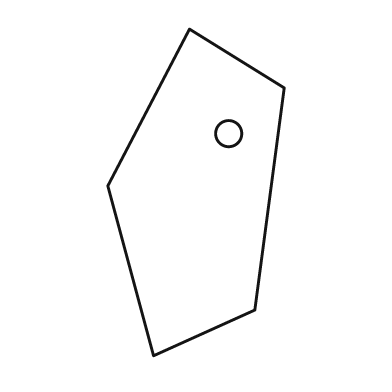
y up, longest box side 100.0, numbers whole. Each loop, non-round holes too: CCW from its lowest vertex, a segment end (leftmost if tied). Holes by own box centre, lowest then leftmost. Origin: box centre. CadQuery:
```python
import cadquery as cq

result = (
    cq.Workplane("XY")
    .moveTo(-13.0, -50.0)
    .lineTo(18.0, -36.0)
    .lineTo(27.0, 32.0)
    .lineTo(-2.0, 50.0)
    .lineTo(-27.0, 2.0)
    .close()
    .moveTo(10.0, 18.0)
    .circle(4.0)
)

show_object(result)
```